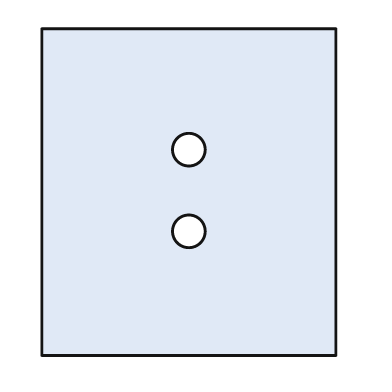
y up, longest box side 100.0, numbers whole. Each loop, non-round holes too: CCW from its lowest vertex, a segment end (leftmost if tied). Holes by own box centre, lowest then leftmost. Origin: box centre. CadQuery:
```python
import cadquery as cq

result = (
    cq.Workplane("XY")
    .moveTo(-45.0, -50.0)
    .lineTo(45.0, -50.0)
    .lineTo(45.0, 50.0)
    .lineTo(-45.0, 50.0)
    .close()
    .moveTo(0.0, -12.0)
    .circle(5.0)
    .moveTo(0.0, 13.0)
    .circle(5.0)
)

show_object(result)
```